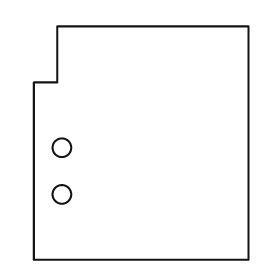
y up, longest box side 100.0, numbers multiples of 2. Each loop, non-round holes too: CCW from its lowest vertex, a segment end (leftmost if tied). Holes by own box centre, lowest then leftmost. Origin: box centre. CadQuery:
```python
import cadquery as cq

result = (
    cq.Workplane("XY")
    .moveTo(-46.0, -50.0)
    .lineTo(46.0, -50.0)
    .lineTo(46.0, 50.0)
    .lineTo(-36.0, 50.0)
    .lineTo(-36.0, 26.0)
    .lineTo(-46.0, 26.0)
    .close()
    .moveTo(-34.0, -22.0)
    .circle(4.0)
    .moveTo(-34.0, -2.0)
    .circle(4.0)
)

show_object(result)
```